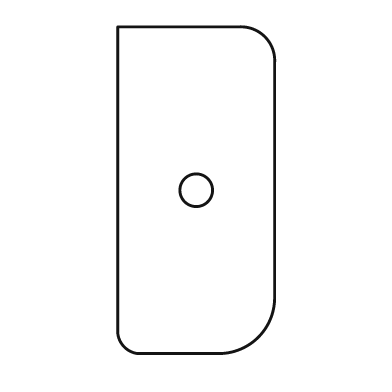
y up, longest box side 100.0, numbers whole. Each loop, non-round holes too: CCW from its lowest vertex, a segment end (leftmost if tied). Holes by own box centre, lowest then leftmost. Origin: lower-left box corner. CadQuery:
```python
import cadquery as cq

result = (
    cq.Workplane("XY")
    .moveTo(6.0, 0.0)
    .lineTo(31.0, 0.0)
    .threePointArc((43.0, 5.0), (48.0, 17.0))
    .lineTo(48.0, 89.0)
    .threePointArc((45.0, 97.0), (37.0, 100.0))
    .lineTo(0.0, 100.0)
    .lineTo(0.0, 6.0)
    .threePointArc((2.0, 2.0), (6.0, 0.0))
    .close()
    .moveTo(24.0, 50.0)
    .circle(5.0)
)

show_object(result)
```